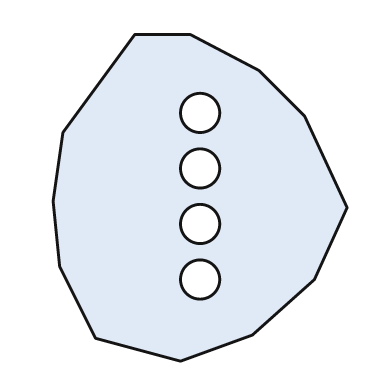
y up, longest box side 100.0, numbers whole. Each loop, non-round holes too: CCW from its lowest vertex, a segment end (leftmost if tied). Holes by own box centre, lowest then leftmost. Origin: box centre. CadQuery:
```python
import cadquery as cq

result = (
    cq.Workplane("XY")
    .moveTo(-6.0, -50.0)
    .lineTo(16.0, -42.0)
    .lineTo(35.0, -25.0)
    .lineTo(45.0, -3.0)
    .lineTo(32.0, 25.0)
    .lineTo(18.0, 39.0)
    .lineTo(-3.0, 50.0)
    .lineTo(-20.0, 50.0)
    .lineTo(-42.0, 20.0)
    .lineTo(-45.0, -1.0)
    .lineTo(-43.0, -21.0)
    .lineTo(-32.0, -43.0)
    .close()
    .moveTo(0.0, -25.0)
    .circle(6.0)
    .moveTo(0.0, -8.0)
    .circle(6.0)
    .moveTo(0.0, 9.0)
    .circle(6.0)
    .moveTo(0.0, 26.0)
    .circle(6.0)
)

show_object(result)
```